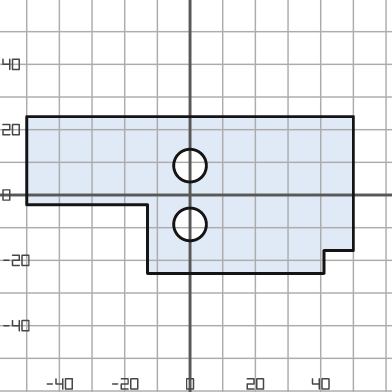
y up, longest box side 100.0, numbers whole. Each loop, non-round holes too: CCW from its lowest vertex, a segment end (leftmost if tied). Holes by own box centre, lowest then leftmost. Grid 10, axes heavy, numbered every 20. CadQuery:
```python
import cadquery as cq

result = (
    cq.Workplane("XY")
    .moveTo(-13.0, -24.0)
    .lineTo(41.0, -24.0)
    .lineTo(41.0, -17.0)
    .lineTo(50.0, -17.0)
    .lineTo(50.0, 24.0)
    .lineTo(-50.0, 24.0)
    .lineTo(-50.0, -3.0)
    .lineTo(-13.0, -3.0)
    .close()
    .moveTo(0.0, -9.0)
    .circle(5.0)
    .moveTo(0.0, 9.0)
    .circle(5.0)
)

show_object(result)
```